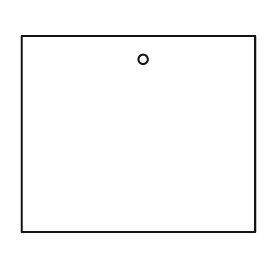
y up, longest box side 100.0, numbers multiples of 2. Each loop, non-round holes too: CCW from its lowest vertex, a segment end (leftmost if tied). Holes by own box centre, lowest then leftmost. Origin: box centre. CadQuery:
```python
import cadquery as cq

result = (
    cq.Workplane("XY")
    .moveTo(-50.0, -42.0)
    .lineTo(50.0, -42.0)
    .lineTo(50.0, 42.0)
    .lineTo(-50.0, 42.0)
    .close()
    .moveTo(2.0, 32.0)
    .circle(2.0)
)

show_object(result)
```